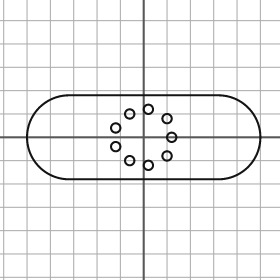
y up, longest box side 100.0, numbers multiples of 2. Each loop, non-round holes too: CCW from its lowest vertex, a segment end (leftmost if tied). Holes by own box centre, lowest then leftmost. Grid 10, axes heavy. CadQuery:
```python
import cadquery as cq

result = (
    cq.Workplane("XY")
    .moveTo(-32.0, -18.0)
    .lineTo(32.0, -18.0)
    .threePointArc((50.0, 0.0), (32.0, 18.0))
    .lineTo(-32.0, 18.0)
    .threePointArc((-50.0, 0.0), (-32.0, -18.0))
    .close()
    .moveTo(2.0, -12.0)
    .circle(2.0)
    .moveTo(-6.0, -10.0)
    .circle(2.0)
    .moveTo(10.0, -8.0)
    .circle(2.0)
    .moveTo(-12.0, -4.0)
    .circle(2.0)
    .moveTo(12.0, 0.0)
    .circle(2.0)
    .moveTo(-12.0, 4.0)
    .circle(2.0)
    .moveTo(10.0, 8.0)
    .circle(2.0)
    .moveTo(-6.0, 10.0)
    .circle(2.0)
    .moveTo(2.0, 12.0)
    .circle(2.0)
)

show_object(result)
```